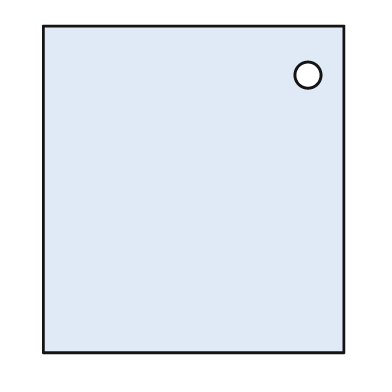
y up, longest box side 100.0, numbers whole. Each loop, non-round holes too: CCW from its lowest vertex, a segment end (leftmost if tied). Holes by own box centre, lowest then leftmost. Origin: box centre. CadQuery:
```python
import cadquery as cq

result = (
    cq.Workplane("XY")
    .moveTo(-46.0, -50.0)
    .lineTo(46.0, -50.0)
    .lineTo(46.0, 50.0)
    .lineTo(-46.0, 50.0)
    .close()
    .moveTo(35.0, 35.0)
    .circle(4.0)
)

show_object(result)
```